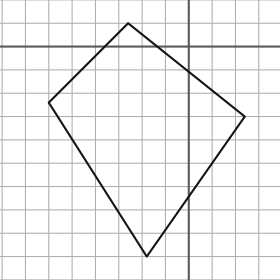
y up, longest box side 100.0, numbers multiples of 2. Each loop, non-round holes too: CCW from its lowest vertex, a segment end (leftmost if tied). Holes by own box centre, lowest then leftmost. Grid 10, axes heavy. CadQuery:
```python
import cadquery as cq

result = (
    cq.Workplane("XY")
    .moveTo(-18.0, -90.0)
    .lineTo(24.0, -30.0)
    .lineTo(-26.0, 10.0)
    .lineTo(-60.0, -24.0)
    .close()
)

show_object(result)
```